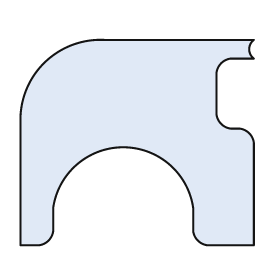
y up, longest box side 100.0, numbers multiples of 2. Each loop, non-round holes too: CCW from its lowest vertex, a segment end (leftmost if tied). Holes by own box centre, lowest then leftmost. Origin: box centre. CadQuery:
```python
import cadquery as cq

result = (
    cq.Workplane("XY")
    .moveTo(-50.0, -44.0)
    .lineTo(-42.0, -44.0)
    .threePointArc((-38.0, -42.0), (-36.0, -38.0))
    .lineTo(-36.0, -28.0)
    .threePointArc((-6.0, -2.0), (24.0, -28.0))
    .lineTo(24.0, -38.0)
    .threePointArc((26.0, -42.0), (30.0, -44.0))
    .lineTo(50.0, -44.0)
    .lineTo(50.0, 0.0)
    .threePointArc((48.0, 4.0), (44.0, 6.0))
    .lineTo(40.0, 6.0)
    .threePointArc((36.0, 8.0), (34.0, 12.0))
    .lineTo(34.0, 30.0)
    .threePointArc((36.0, 34.0), (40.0, 36.0))
    .lineTo(50.0, 36.0)
    .threePointArc((48.0, 40.0), (50.0, 44.0))
    .lineTo(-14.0, 44.0)
    .threePointArc((-40.0, 34.0), (-50.0, 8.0))
    .close()
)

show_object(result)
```